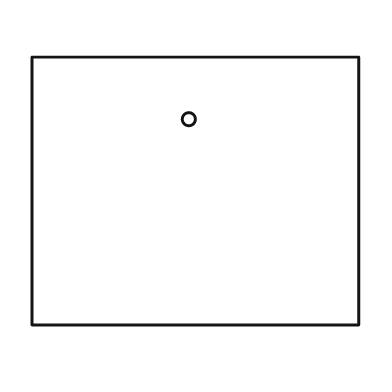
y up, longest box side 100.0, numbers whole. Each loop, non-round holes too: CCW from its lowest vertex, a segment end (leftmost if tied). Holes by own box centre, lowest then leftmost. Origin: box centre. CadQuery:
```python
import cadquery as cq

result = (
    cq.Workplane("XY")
    .moveTo(-50.0, -41.0)
    .lineTo(50.0, -41.0)
    .lineTo(50.0, 41.0)
    .lineTo(-50.0, 41.0)
    .close()
    .moveTo(-2.0, 22.0)
    .circle(2.0)
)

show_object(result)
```